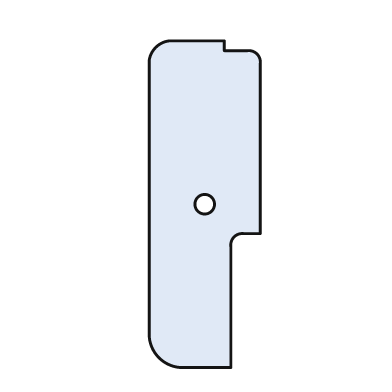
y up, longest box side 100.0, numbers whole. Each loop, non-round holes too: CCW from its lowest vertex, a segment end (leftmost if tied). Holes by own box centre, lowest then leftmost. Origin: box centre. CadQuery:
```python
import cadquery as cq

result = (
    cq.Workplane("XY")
    .moveTo(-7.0, -50.0)
    .lineTo(8.0, -50.0)
    .lineTo(8.0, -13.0)
    .threePointArc((9.0, -10.0), (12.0, -9.0))
    .lineTo(17.0, -9.0)
    .lineTo(17.0, 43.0)
    .threePointArc((16.0, 46.0), (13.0, 47.0))
    .lineTo(6.0, 47.0)
    .lineTo(6.0, 50.0)
    .lineTo(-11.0, 50.0)
    .threePointArc((-15.0, 48.0), (-17.0, 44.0))
    .lineTo(-17.0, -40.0)
    .threePointArc((-14.0, -47.0), (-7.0, -50.0))
    .close()
    .moveTo(0.0, 0.0)
    .circle(3.0)
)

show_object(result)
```